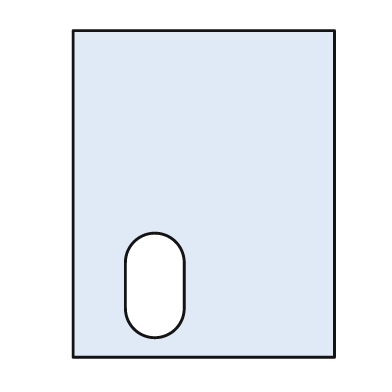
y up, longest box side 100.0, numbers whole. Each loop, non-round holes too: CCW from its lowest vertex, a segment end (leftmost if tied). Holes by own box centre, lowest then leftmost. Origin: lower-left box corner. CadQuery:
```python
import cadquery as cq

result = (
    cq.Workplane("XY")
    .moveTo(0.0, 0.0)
    .lineTo(80.0, 0.0)
    .lineTo(80.0, 100.0)
    .lineTo(0.0, 100.0)
    .close()
    .moveTo(16.0, 15.0)
    .threePointArc((25.0, 6.0), (34.0, 15.0))
    .lineTo(34.0, 29.0)
    .threePointArc((25.0, 38.0), (16.0, 29.0))
    .close()
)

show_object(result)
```